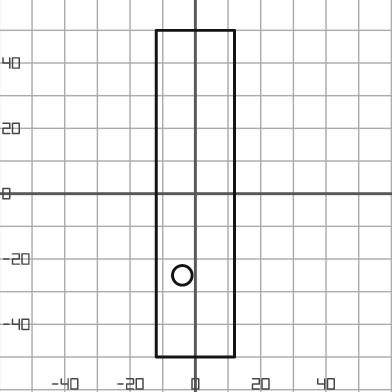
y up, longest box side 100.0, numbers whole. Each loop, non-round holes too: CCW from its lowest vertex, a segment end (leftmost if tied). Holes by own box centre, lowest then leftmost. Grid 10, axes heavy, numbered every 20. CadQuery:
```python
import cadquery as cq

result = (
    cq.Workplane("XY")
    .moveTo(-12.0, -50.0)
    .lineTo(12.0, -50.0)
    .lineTo(12.0, 50.0)
    .lineTo(-12.0, 50.0)
    .close()
    .moveTo(-4.0, -25.0)
    .circle(3.0)
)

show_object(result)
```